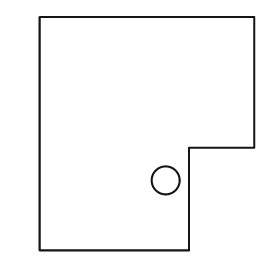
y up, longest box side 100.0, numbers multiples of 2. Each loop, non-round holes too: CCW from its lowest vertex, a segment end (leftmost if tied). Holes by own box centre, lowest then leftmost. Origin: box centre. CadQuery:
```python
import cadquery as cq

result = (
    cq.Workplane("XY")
    .moveTo(-46.0, -50.0)
    .lineTo(18.0, -50.0)
    .lineTo(18.0, -6.0)
    .lineTo(46.0, -6.0)
    .lineTo(46.0, 50.0)
    .lineTo(-46.0, 50.0)
    .close()
    .moveTo(8.0, -20.0)
    .circle(6.0)
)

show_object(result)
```